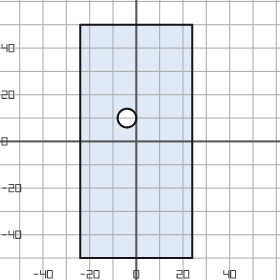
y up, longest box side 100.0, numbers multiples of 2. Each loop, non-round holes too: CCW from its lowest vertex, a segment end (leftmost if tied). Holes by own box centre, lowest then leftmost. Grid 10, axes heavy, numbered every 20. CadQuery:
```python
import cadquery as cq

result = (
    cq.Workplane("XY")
    .moveTo(-24.0, -50.0)
    .lineTo(24.0, -50.0)
    .lineTo(24.0, 50.0)
    .lineTo(-24.0, 50.0)
    .close()
    .moveTo(-4.0, 10.0)
    .circle(4.0)
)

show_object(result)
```